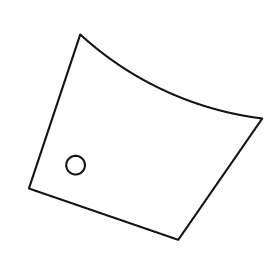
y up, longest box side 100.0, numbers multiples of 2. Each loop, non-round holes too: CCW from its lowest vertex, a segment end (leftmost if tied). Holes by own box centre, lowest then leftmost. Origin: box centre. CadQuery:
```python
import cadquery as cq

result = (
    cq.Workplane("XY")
    .moveTo(14.0, -44.0)
    .lineTo(50.0, 8.0)
    .threePointArc((8.0, 20.0), (-28.0, 44.0))
    .lineTo(-50.0, -22.0)
    .close()
    .moveTo(-30.0, -12.0)
    .circle(4.0)
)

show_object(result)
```